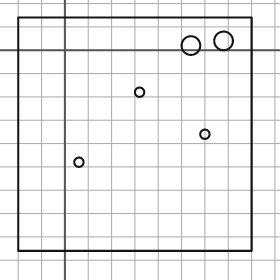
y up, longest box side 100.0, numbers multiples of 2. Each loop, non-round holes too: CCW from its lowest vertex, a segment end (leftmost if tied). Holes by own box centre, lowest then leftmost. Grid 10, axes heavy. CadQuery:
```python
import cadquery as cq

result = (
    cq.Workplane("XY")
    .moveTo(-20.0, -86.0)
    .lineTo(80.0, -86.0)
    .lineTo(80.0, 14.0)
    .lineTo(-20.0, 14.0)
    .close()
    .moveTo(6.0, -48.0)
    .circle(2.0)
    .moveTo(60.0, -36.0)
    .circle(2.0)
    .moveTo(32.0, -18.0)
    .circle(2.0)
    .moveTo(54.0, 2.0)
    .circle(4.0)
    .moveTo(68.0, 4.0)
    .circle(4.0)
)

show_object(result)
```